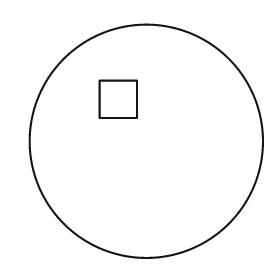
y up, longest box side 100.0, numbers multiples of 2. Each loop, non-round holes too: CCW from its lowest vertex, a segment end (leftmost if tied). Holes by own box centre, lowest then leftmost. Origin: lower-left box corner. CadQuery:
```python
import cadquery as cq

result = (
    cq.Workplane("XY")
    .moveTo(50.0, 50.0)
    .circle(50.0)
    .moveTo(30.0, 60.0)
    .lineTo(46.0, 60.0)
    .lineTo(46.0, 76.0)
    .lineTo(30.0, 76.0)
    .close()
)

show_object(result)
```